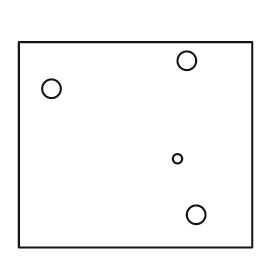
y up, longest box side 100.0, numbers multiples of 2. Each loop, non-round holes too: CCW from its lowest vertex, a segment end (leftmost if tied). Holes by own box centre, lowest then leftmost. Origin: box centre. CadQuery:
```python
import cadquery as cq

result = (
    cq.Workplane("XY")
    .moveTo(-50.0, -44.0)
    .lineTo(50.0, -44.0)
    .lineTo(50.0, 44.0)
    .lineTo(-50.0, 44.0)
    .close()
    .moveTo(26.0, -30.0)
    .circle(4.0)
    .moveTo(18.0, -6.0)
    .circle(2.0)
    .moveTo(-36.0, 24.0)
    .circle(4.0)
    .moveTo(22.0, 36.0)
    .circle(4.0)
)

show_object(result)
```